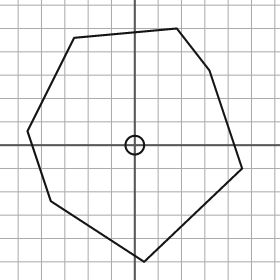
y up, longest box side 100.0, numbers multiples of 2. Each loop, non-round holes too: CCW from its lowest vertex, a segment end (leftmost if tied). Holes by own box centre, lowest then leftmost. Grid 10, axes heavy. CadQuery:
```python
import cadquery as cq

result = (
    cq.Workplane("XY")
    .moveTo(4.0, -50.0)
    .lineTo(46.0, -10.0)
    .lineTo(32.0, 32.0)
    .lineTo(18.0, 50.0)
    .lineTo(-26.0, 46.0)
    .lineTo(-46.0, 6.0)
    .lineTo(-36.0, -24.0)
    .close()
    .moveTo(0.0, 0.0)
    .circle(4.0)
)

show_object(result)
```